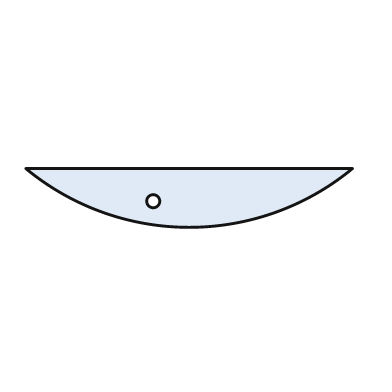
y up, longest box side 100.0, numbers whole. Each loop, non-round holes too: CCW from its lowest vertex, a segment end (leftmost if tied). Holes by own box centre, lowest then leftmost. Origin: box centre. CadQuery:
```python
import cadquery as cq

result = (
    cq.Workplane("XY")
    .moveTo(-50.0, 9.0)
    .threePointArc((0.0, -9.0), (50.0, 9.0))
    .close()
    .moveTo(-11.0, -1.0)
    .circle(2.0)
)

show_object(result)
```